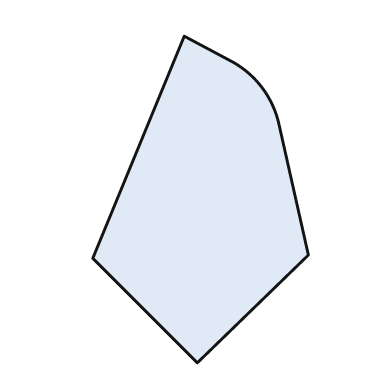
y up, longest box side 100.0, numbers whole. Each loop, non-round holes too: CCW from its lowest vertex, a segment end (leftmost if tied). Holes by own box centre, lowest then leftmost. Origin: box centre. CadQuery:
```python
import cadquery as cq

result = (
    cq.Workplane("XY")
    .moveTo(-1.0, -50.0)
    .lineTo(33.0, -17.0)
    .lineTo(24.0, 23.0)
    .threePointArc((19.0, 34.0), (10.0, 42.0))
    .lineTo(-5.0, 50.0)
    .lineTo(-33.0, -18.0)
    .close()
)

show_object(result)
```